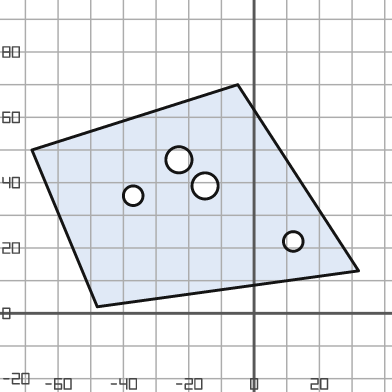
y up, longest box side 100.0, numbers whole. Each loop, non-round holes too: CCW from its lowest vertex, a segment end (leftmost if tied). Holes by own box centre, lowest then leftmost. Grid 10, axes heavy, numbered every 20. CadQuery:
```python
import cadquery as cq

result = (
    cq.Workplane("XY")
    .moveTo(-48.0, 2.0)
    .lineTo(32.0, 13.0)
    .lineTo(-5.0, 70.0)
    .lineTo(-68.0, 50.0)
    .close()
    .moveTo(12.0, 22.0)
    .circle(3.0)
    .moveTo(-37.0, 36.0)
    .circle(3.0)
    .moveTo(-15.0, 39.0)
    .circle(4.0)
    .moveTo(-23.0, 47.0)
    .circle(4.0)
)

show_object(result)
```